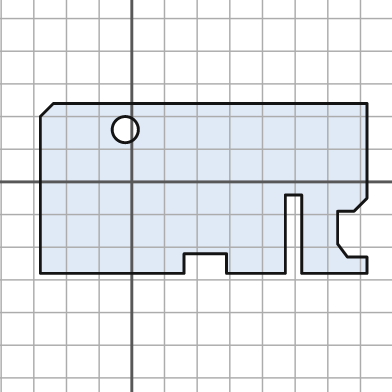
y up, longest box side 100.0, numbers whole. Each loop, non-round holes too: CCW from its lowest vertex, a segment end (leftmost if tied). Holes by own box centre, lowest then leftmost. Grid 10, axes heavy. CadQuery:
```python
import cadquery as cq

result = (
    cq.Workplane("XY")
    .moveTo(-28.0, -28.0)
    .lineTo(16.0, -28.0)
    .lineTo(16.0, -22.0)
    .lineTo(29.0, -22.0)
    .lineTo(29.0, -28.0)
    .lineTo(47.0, -28.0)
    .lineTo(47.0, -4.0)
    .lineTo(52.0, -4.0)
    .lineTo(52.0, -28.0)
    .lineTo(72.0, -28.0)
    .lineTo(72.0, -23.0)
    .lineTo(66.0, -23.0)
    .lineTo(63.0, -19.0)
    .lineTo(63.0, -9.0)
    .lineTo(68.0, -9.0)
    .lineTo(72.0, -5.0)
    .lineTo(72.0, 24.0)
    .lineTo(-24.0, 24.0)
    .lineTo(-28.0, 20.0)
    .close()
    .moveTo(-2.0, 16.0)
    .circle(4.0)
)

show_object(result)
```